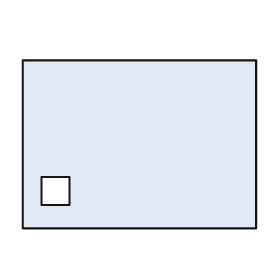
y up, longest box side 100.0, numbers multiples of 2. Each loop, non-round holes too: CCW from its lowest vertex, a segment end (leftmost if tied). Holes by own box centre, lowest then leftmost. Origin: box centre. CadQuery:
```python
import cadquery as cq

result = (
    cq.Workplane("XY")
    .moveTo(-50.0, -36.0)
    .lineTo(50.0, -36.0)
    .lineTo(50.0, 36.0)
    .lineTo(-50.0, 36.0)
    .close()
    .moveTo(-42.0, -26.0)
    .lineTo(-30.0, -26.0)
    .lineTo(-30.0, -14.0)
    .lineTo(-42.0, -14.0)
    .close()
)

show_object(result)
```